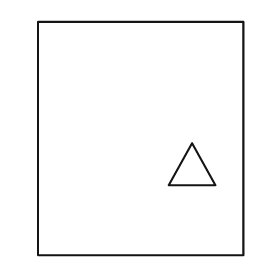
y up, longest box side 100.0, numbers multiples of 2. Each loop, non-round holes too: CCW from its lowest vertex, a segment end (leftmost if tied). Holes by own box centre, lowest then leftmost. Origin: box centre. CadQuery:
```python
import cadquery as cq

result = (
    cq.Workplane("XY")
    .moveTo(-44.0, -50.0)
    .lineTo(44.0, -50.0)
    .lineTo(44.0, 50.0)
    .lineTo(-44.0, 50.0)
    .close()
    .moveTo(12.0, -20.0)
    .lineTo(32.0, -20.0)
    .lineTo(22.0, -2.0)
    .close()
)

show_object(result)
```